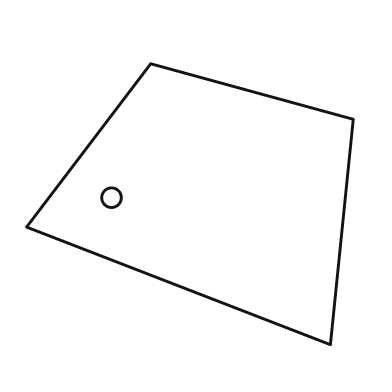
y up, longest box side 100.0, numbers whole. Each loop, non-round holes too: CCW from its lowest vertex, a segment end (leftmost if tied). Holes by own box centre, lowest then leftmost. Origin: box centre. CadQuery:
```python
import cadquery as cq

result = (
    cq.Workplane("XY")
    .moveTo(43.0, -43.0)
    .lineTo(50.0, 26.0)
    .lineTo(-12.0, 43.0)
    .lineTo(-50.0, -7.0)
    .close()
    .moveTo(-24.0, 2.0)
    .circle(3.0)
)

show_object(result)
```